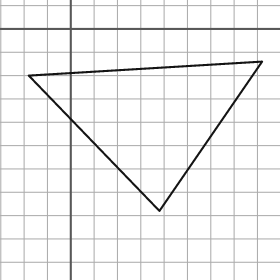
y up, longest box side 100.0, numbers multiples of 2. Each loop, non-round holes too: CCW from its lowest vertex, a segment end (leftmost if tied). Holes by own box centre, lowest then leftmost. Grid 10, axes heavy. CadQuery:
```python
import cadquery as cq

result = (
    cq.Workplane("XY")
    .moveTo(38.0, -78.0)
    .lineTo(82.0, -14.0)
    .lineTo(-18.0, -20.0)
    .close()
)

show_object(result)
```